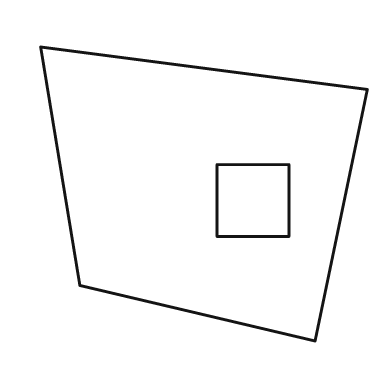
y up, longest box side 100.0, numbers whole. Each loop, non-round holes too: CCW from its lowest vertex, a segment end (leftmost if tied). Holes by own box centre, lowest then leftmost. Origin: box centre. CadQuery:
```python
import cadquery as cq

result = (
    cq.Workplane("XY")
    .moveTo(34.0, -45.0)
    .lineTo(50.0, 32.0)
    .lineTo(-50.0, 45.0)
    .lineTo(-38.0, -28.0)
    .close()
    .moveTo(4.0, -13.0)
    .lineTo(26.0, -13.0)
    .lineTo(26.0, 9.0)
    .lineTo(4.0, 9.0)
    .close()
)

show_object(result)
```